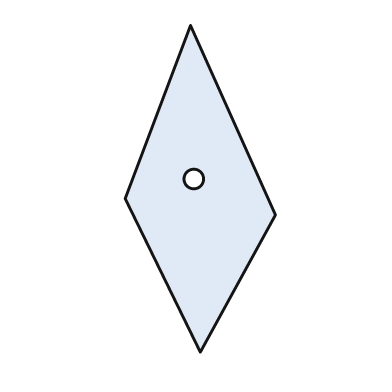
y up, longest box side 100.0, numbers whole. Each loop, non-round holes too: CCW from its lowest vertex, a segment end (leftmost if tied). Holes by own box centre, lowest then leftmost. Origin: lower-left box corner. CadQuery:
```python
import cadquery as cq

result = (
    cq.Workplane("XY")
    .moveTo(23.0, 0.0)
    .lineTo(46.0, 42.0)
    .lineTo(20.0, 100.0)
    .lineTo(0.0, 47.0)
    .close()
    .moveTo(21.0, 53.0)
    .circle(3.0)
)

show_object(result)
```